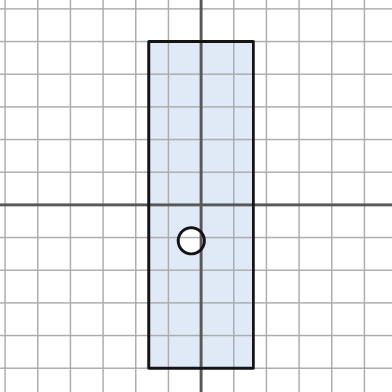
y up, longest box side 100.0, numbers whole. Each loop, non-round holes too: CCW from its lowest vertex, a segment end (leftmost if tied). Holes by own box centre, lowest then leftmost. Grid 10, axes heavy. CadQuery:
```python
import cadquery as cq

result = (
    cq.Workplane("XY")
    .moveTo(-16.0, -50.0)
    .lineTo(16.0, -50.0)
    .lineTo(16.0, 50.0)
    .lineTo(-16.0, 50.0)
    .close()
    .moveTo(-3.0, -11.0)
    .circle(4.0)
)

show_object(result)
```